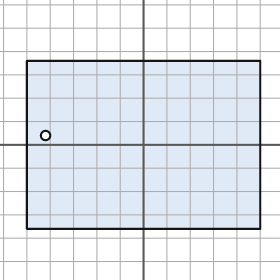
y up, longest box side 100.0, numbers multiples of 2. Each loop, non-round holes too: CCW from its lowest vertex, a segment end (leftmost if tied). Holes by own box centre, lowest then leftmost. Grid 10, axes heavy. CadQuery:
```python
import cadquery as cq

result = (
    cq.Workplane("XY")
    .moveTo(-50.0, -36.0)
    .lineTo(50.0, -36.0)
    .lineTo(50.0, 36.0)
    .lineTo(-50.0, 36.0)
    .close()
    .moveTo(-42.0, 4.0)
    .circle(2.0)
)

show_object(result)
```